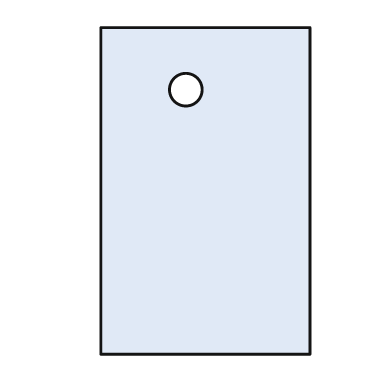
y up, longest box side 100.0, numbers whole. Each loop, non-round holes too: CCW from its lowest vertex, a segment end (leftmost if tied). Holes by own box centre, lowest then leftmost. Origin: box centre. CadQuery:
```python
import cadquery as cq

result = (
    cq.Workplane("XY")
    .moveTo(-32.0, -50.0)
    .lineTo(32.0, -50.0)
    .lineTo(32.0, 50.0)
    .lineTo(-32.0, 50.0)
    .close()
    .moveTo(-6.0, 31.0)
    .circle(5.0)
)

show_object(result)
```